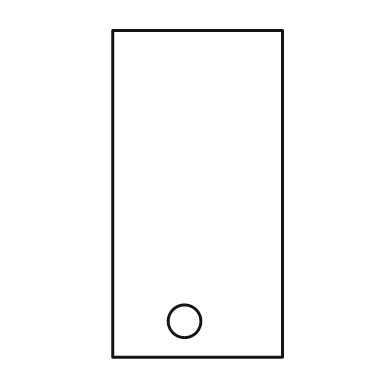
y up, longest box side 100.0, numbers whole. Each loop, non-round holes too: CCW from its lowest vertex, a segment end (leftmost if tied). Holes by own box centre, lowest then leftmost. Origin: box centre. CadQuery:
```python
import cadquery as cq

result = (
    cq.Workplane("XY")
    .moveTo(-26.0, -50.0)
    .lineTo(26.0, -50.0)
    .lineTo(26.0, 50.0)
    .lineTo(-26.0, 50.0)
    .close()
    .moveTo(-4.0, -39.0)
    .circle(5.0)
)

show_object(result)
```